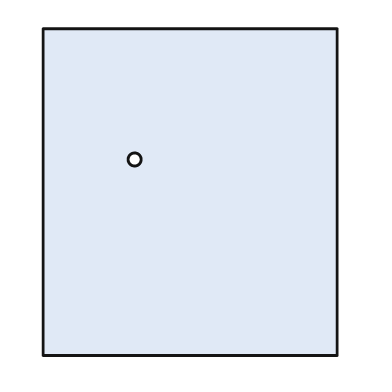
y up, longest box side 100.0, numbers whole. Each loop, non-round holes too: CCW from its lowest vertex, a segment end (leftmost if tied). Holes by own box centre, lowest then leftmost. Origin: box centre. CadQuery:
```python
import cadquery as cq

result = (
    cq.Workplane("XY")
    .moveTo(-45.0, -50.0)
    .lineTo(45.0, -50.0)
    .lineTo(45.0, 50.0)
    .lineTo(-45.0, 50.0)
    .close()
    .moveTo(-17.0, 10.0)
    .circle(2.0)
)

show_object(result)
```